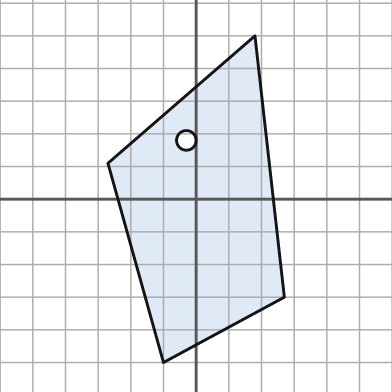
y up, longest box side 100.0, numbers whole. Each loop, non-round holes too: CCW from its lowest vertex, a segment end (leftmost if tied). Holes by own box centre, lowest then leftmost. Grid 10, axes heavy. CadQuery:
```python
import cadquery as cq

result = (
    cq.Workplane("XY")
    .moveTo(-10.0, -50.0)
    .lineTo(27.0, -30.0)
    .lineTo(18.0, 50.0)
    .lineTo(-27.0, 11.0)
    .close()
    .moveTo(-3.0, 18.0)
    .circle(3.0)
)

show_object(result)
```